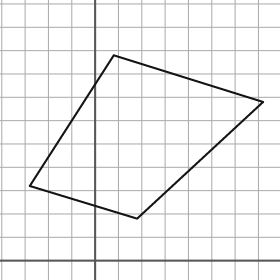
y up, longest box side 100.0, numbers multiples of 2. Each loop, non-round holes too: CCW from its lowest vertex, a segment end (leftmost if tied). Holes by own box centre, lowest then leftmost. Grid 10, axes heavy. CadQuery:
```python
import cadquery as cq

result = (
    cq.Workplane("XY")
    .moveTo(18.0, 18.0)
    .lineTo(72.0, 68.0)
    .lineTo(8.0, 88.0)
    .lineTo(-28.0, 32.0)
    .close()
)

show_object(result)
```